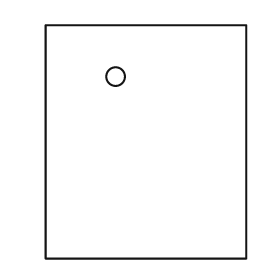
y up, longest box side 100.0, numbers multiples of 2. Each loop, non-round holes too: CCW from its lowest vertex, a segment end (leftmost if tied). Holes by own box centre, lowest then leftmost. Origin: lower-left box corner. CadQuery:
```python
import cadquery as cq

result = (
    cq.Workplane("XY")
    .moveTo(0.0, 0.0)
    .lineTo(86.0, 0.0)
    .lineTo(86.0, 100.0)
    .lineTo(0.0, 100.0)
    .close()
    .moveTo(30.0, 78.0)
    .circle(4.0)
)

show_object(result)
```